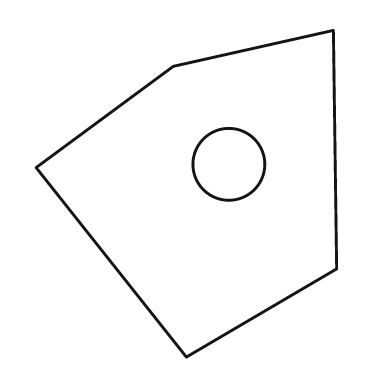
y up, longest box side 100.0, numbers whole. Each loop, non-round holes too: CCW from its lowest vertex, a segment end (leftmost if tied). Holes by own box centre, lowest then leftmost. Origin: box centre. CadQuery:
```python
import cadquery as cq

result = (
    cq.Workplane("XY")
    .moveTo(0.0, -50.0)
    .lineTo(46.0, -23.0)
    .lineTo(45.0, 50.0)
    .lineTo(-4.0, 39.0)
    .lineTo(-46.0, 8.0)
    .close()
    .moveTo(13.0, 9.0)
    .circle(11.0)
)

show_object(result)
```